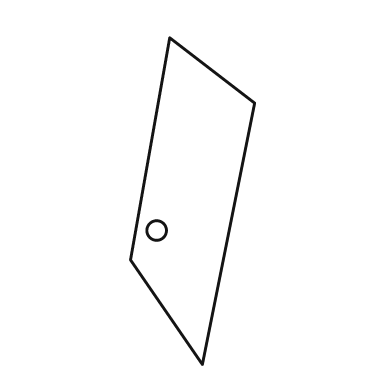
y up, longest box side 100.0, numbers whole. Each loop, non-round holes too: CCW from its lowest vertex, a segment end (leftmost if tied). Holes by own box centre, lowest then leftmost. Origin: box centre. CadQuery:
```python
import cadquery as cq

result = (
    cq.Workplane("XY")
    .moveTo(3.0, -50.0)
    .lineTo(19.0, 30.0)
    .lineTo(-7.0, 50.0)
    .lineTo(-19.0, -18.0)
    .close()
    .moveTo(-11.0, -9.0)
    .circle(3.0)
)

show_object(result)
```